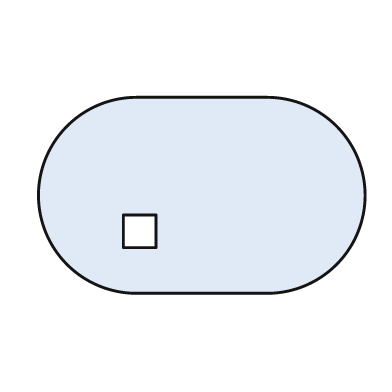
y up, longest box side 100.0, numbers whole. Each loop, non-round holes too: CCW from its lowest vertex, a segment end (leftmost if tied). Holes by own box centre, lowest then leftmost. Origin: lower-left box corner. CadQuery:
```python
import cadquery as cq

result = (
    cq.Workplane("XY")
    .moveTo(30.0, 0.0)
    .lineTo(70.0, 0.0)
    .threePointArc((100.0, 30.0), (70.0, 60.0))
    .lineTo(30.0, 60.0)
    .threePointArc((0.0, 30.0), (30.0, 0.0))
    .close()
    .moveTo(26.0, 14.0)
    .lineTo(36.0, 14.0)
    .lineTo(36.0, 24.0)
    .lineTo(26.0, 24.0)
    .close()
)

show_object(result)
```